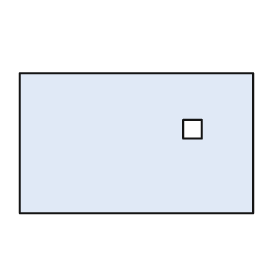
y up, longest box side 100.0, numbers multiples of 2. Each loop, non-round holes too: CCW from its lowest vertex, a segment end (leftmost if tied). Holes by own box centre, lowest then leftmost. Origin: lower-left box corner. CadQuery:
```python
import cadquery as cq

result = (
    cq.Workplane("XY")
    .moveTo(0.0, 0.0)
    .lineTo(100.0, 0.0)
    .lineTo(100.0, 60.0)
    .lineTo(0.0, 60.0)
    .close()
    .moveTo(70.0, 32.0)
    .lineTo(78.0, 32.0)
    .lineTo(78.0, 40.0)
    .lineTo(70.0, 40.0)
    .close()
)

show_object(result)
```